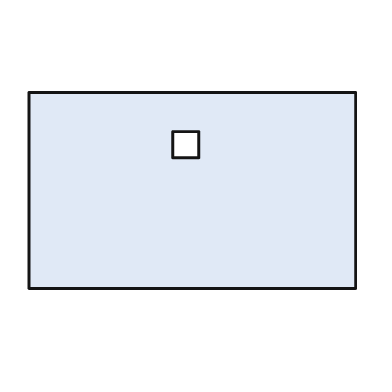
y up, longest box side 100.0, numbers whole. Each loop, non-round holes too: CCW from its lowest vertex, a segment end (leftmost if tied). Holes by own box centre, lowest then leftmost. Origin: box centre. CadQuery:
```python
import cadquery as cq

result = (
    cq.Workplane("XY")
    .moveTo(-50.0, -30.0)
    .lineTo(50.0, -30.0)
    .lineTo(50.0, 30.0)
    .lineTo(-50.0, 30.0)
    .close()
    .moveTo(-6.0, 10.0)
    .lineTo(2.0, 10.0)
    .lineTo(2.0, 18.0)
    .lineTo(-6.0, 18.0)
    .close()
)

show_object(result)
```